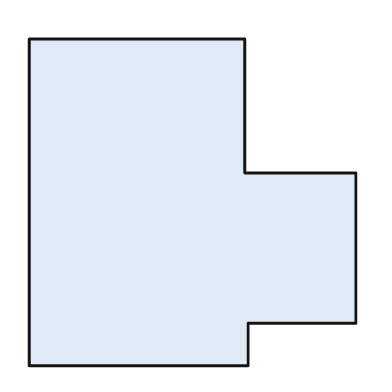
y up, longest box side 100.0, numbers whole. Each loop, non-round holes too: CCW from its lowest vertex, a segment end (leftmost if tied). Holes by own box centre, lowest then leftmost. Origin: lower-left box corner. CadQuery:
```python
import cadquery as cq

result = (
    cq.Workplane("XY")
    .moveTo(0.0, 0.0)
    .lineTo(67.0, 0.0)
    .lineTo(67.0, 13.0)
    .lineTo(100.0, 13.0)
    .lineTo(100.0, 59.0)
    .lineTo(66.0, 59.0)
    .lineTo(66.0, 100.0)
    .lineTo(0.0, 100.0)
    .close()
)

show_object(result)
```